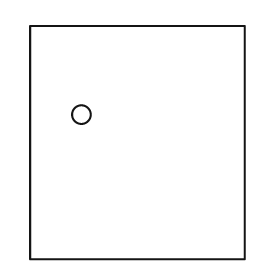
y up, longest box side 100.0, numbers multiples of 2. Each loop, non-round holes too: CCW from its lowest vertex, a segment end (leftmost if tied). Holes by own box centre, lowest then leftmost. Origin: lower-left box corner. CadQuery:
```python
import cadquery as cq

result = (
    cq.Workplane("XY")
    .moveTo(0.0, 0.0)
    .lineTo(92.0, 0.0)
    .lineTo(92.0, 100.0)
    .lineTo(0.0, 100.0)
    .close()
    .moveTo(22.0, 62.0)
    .circle(4.0)
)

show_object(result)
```